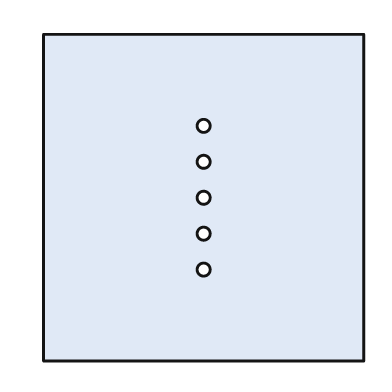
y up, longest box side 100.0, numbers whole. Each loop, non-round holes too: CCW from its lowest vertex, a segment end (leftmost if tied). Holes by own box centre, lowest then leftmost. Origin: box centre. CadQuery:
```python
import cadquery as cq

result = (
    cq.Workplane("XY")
    .moveTo(-49.0, -50.0)
    .lineTo(49.0, -50.0)
    .lineTo(49.0, 50.0)
    .lineTo(-49.0, 50.0)
    .close()
    .moveTo(0.0, -22.0)
    .circle(2.0)
    .moveTo(0.0, -11.0)
    .circle(2.0)
    .moveTo(0.0, 0.0)
    .circle(2.0)
    .moveTo(0.0, 11.0)
    .circle(2.0)
    .moveTo(0.0, 22.0)
    .circle(2.0)
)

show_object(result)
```